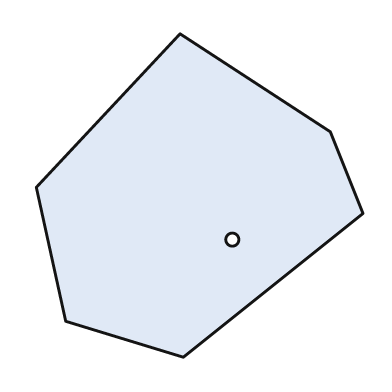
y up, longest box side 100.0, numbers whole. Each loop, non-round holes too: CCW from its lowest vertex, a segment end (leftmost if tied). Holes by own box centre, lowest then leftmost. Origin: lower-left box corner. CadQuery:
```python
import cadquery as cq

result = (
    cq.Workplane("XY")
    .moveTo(45.0, 0.0)
    .lineTo(100.0, 44.0)
    .lineTo(90.0, 69.0)
    .lineTo(44.0, 99.0)
    .lineTo(0.0, 52.0)
    .lineTo(9.0, 11.0)
    .close()
    .moveTo(60.0, 36.0)
    .circle(2.0)
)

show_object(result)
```